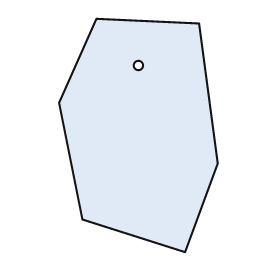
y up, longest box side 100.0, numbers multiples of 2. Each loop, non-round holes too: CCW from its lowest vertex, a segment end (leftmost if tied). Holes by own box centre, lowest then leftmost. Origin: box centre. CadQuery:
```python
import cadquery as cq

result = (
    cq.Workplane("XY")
    .moveTo(20.0, -50.0)
    .lineTo(34.0, -12.0)
    .lineTo(26.0, 48.0)
    .lineTo(-18.0, 50.0)
    .lineTo(-34.0, 14.0)
    .lineTo(-24.0, -36.0)
    .close()
    .moveTo(0.0, 30.0)
    .circle(2.0)
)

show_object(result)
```